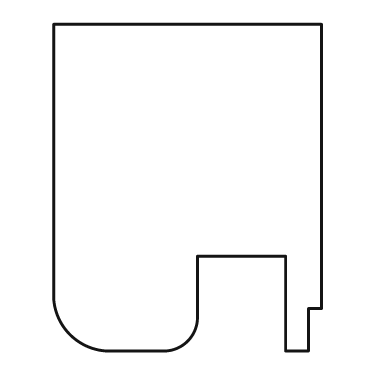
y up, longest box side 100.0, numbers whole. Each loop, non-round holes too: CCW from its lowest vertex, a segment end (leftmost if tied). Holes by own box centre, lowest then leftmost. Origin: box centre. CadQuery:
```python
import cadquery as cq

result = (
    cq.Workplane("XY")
    .moveTo(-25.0, -50.0)
    .lineTo(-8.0, -50.0)
    .threePointArc((0.0, -47.0), (3.0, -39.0))
    .lineTo(3.0, -21.0)
    .lineTo(30.0, -21.0)
    .lineTo(30.0, -50.0)
    .lineTo(37.0, -50.0)
    .lineTo(37.0, -37.0)
    .lineTo(41.0, -37.0)
    .lineTo(41.0, 50.0)
    .lineTo(-41.0, 50.0)
    .lineTo(-41.0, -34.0)
    .threePointArc((-36.0, -45.0), (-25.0, -50.0))
    .close()
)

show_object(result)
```